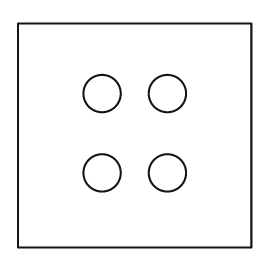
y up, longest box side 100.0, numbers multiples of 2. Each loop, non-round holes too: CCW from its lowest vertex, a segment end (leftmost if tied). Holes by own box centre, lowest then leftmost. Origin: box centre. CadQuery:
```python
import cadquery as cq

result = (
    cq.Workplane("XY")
    .moveTo(-50.0, -48.0)
    .lineTo(50.0, -48.0)
    .lineTo(50.0, 48.0)
    .lineTo(-50.0, 48.0)
    .close()
    .moveTo(-14.0, -16.0)
    .circle(8.0)
    .moveTo(14.0, -16.0)
    .circle(8.0)
    .moveTo(-14.0, 18.0)
    .circle(8.0)
    .moveTo(14.0, 18.0)
    .circle(8.0)
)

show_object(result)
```